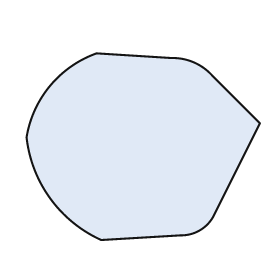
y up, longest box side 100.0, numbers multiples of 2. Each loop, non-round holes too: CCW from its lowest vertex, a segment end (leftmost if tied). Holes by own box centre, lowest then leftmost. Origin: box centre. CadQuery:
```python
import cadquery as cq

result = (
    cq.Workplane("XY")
    .moveTo(-18.0, -40.0)
    .lineTo(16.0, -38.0)
    .threePointArc((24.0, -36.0), (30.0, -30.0))
    .lineTo(50.0, 10.0)
    .lineTo(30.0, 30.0)
    .threePointArc((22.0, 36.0), (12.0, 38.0))
    .lineTo(-20.0, 40.0)
    .threePointArc((-40.0, 26.0), (-50.0, 4.0))
    .threePointArc((-40.0, -22.0), (-18.0, -40.0))
    .close()
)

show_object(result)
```